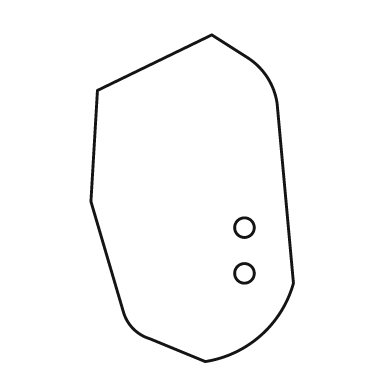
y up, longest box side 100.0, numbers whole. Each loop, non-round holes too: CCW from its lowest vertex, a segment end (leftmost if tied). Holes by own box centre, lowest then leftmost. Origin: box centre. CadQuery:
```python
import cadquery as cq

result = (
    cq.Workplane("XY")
    .moveTo(4.0, -50.0)
    .threePointArc((21.0, -42.0), (31.0, -26.0))
    .lineTo(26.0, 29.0)
    .threePointArc((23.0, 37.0), (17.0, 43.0))
    .lineTo(6.0, 50.0)
    .lineTo(-29.0, 33.0)
    .lineTo(-31.0, -1.0)
    .lineTo(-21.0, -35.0)
    .threePointArc((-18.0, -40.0), (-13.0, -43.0))
    .close()
    .moveTo(16.0, -23.0)
    .circle(3.0)
    .moveTo(16.0, -9.0)
    .circle(3.0)
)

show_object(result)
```